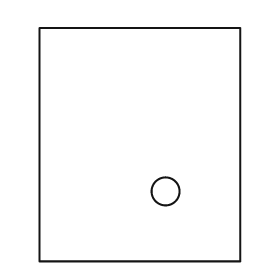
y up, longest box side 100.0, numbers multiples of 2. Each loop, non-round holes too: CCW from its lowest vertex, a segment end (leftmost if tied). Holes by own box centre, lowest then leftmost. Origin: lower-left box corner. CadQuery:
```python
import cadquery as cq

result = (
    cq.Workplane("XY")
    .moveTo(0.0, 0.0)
    .lineTo(86.0, 0.0)
    .lineTo(86.0, 100.0)
    .lineTo(0.0, 100.0)
    .close()
    .moveTo(54.0, 30.0)
    .circle(6.0)
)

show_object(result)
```